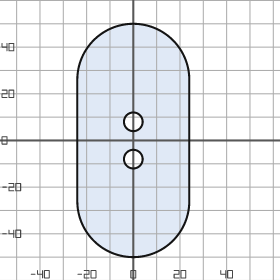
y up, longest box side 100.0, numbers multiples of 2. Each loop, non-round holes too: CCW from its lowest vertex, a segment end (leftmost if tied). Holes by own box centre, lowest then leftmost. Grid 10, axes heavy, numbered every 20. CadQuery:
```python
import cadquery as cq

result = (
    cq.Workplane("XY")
    .moveTo(-24.0, -26.0)
    .threePointArc((0.0, -50.0), (24.0, -26.0))
    .lineTo(24.0, 26.0)
    .threePointArc((0.0, 50.0), (-24.0, 26.0))
    .close()
    .moveTo(0.0, -8.0)
    .circle(4.0)
    .moveTo(0.0, 8.0)
    .circle(4.0)
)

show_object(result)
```